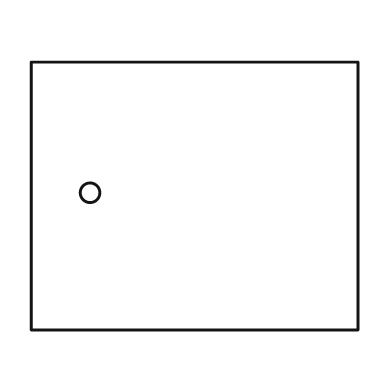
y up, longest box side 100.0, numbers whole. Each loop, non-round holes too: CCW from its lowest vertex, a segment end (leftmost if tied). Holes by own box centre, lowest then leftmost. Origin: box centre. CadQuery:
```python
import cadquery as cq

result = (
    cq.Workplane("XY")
    .moveTo(-50.0, -41.0)
    .lineTo(50.0, -41.0)
    .lineTo(50.0, 41.0)
    .lineTo(-50.0, 41.0)
    .close()
    .moveTo(-32.0, 1.0)
    .circle(3.0)
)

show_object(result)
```